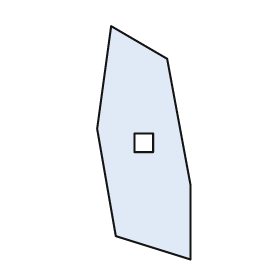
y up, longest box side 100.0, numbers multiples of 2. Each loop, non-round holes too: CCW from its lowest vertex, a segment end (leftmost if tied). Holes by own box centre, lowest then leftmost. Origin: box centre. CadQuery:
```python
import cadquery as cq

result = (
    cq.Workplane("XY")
    .moveTo(20.0, -50.0)
    .lineTo(20.0, -18.0)
    .lineTo(10.0, 36.0)
    .lineTo(-14.0, 50.0)
    .lineTo(-20.0, 6.0)
    .lineTo(-12.0, -40.0)
    .close()
    .moveTo(-4.0, -4.0)
    .lineTo(4.0, -4.0)
    .lineTo(4.0, 4.0)
    .lineTo(-4.0, 4.0)
    .close()
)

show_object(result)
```